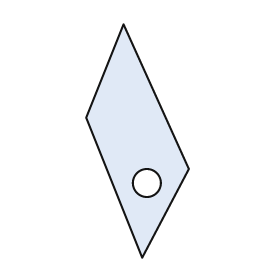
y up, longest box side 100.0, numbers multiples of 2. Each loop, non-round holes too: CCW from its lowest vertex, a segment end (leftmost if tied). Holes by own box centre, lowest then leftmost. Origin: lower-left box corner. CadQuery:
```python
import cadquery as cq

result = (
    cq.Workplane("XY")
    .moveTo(24.0, 0.0)
    .lineTo(44.0, 38.0)
    .lineTo(16.0, 100.0)
    .lineTo(0.0, 60.0)
    .close()
    .moveTo(26.0, 32.0)
    .circle(6.0)
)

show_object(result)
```